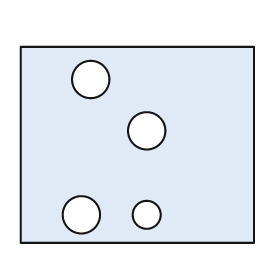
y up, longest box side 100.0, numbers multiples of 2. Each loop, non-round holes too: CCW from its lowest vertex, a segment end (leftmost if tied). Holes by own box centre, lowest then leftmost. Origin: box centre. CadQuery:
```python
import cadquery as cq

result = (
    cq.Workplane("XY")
    .moveTo(-50.0, -42.0)
    .lineTo(50.0, -42.0)
    .lineTo(50.0, 42.0)
    .lineTo(-50.0, 42.0)
    .close()
    .moveTo(-24.0, -30.0)
    .circle(8.0)
    .moveTo(4.0, -30.0)
    .circle(6.0)
    .moveTo(4.0, 6.0)
    .circle(8.0)
    .moveTo(-20.0, 28.0)
    .circle(8.0)
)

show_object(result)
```